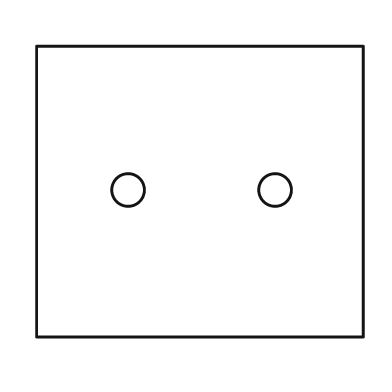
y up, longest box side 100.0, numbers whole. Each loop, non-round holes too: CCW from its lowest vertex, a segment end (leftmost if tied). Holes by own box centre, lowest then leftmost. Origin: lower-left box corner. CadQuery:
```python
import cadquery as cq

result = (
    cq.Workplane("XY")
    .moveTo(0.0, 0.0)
    .lineTo(100.0, 0.0)
    .lineTo(100.0, 89.0)
    .lineTo(0.0, 89.0)
    .close()
    .moveTo(28.0, 45.0)
    .circle(5.0)
    .moveTo(73.0, 45.0)
    .circle(5.0)
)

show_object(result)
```